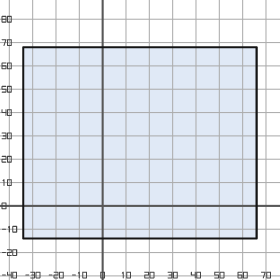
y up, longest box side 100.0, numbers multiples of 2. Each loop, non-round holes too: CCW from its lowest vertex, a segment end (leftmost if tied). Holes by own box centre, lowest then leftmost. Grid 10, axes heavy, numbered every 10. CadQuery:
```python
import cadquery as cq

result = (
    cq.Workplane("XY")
    .moveTo(-34.0, -14.0)
    .lineTo(66.0, -14.0)
    .lineTo(66.0, 68.0)
    .lineTo(-34.0, 68.0)
    .close()
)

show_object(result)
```